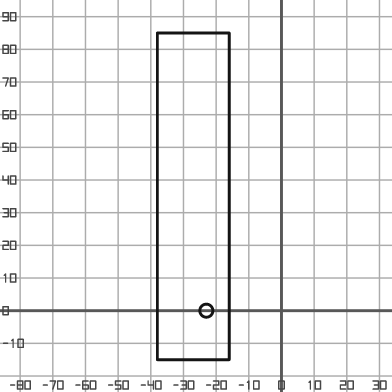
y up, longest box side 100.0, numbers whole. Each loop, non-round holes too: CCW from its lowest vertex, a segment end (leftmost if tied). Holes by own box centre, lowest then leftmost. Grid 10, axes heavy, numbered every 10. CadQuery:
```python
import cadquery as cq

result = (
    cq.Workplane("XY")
    .moveTo(-38.0, -15.0)
    .lineTo(-16.0, -15.0)
    .lineTo(-16.0, 85.0)
    .lineTo(-38.0, 85.0)
    .close()
    .moveTo(-23.0, 0.0)
    .circle(2.0)
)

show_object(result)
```